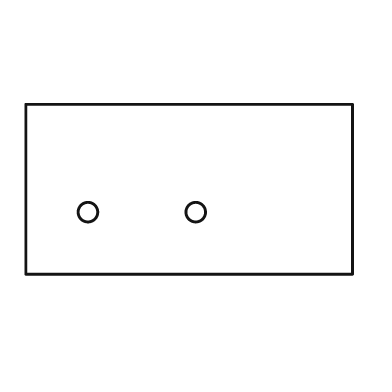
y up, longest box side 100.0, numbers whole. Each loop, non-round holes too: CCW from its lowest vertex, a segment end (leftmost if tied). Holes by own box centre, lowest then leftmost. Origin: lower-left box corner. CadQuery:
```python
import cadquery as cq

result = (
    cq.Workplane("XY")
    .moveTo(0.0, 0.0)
    .lineTo(100.0, 0.0)
    .lineTo(100.0, 52.0)
    .lineTo(0.0, 52.0)
    .close()
    .moveTo(19.0, 19.0)
    .circle(3.0)
    .moveTo(52.0, 19.0)
    .circle(3.0)
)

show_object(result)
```